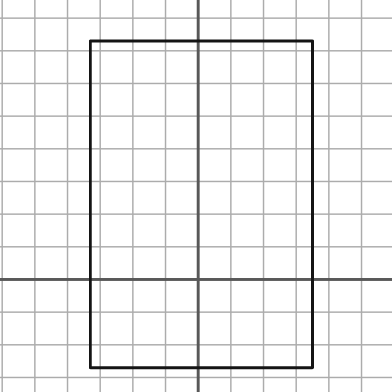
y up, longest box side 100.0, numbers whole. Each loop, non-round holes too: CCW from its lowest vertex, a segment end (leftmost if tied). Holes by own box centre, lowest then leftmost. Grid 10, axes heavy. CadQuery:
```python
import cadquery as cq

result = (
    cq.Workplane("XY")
    .moveTo(-33.0, -27.0)
    .lineTo(35.0, -27.0)
    .lineTo(35.0, 73.0)
    .lineTo(-33.0, 73.0)
    .close()
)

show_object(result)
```